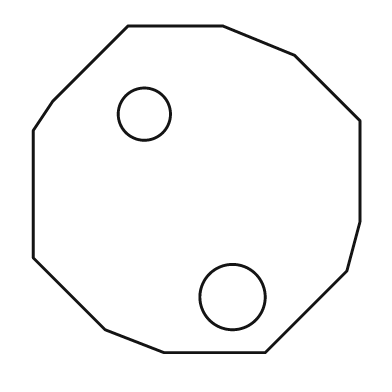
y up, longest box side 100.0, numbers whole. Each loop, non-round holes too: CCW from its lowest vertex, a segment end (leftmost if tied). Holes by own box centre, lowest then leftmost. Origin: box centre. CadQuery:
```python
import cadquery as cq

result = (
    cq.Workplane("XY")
    .moveTo(-10.0, -50.0)
    .lineTo(21.0, -50.0)
    .lineTo(46.0, -25.0)
    .lineTo(50.0, -10.0)
    .lineTo(50.0, 21.0)
    .lineTo(30.0, 41.0)
    .lineTo(8.0, 50.0)
    .lineTo(-21.0, 50.0)
    .lineTo(-44.0, 27.0)
    .lineTo(-50.0, 18.0)
    .lineTo(-50.0, -21.0)
    .lineTo(-28.0, -43.0)
    .close()
    .moveTo(11.0, -33.0)
    .circle(10.0)
    .moveTo(-16.0, 23.0)
    .circle(8.0)
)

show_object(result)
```